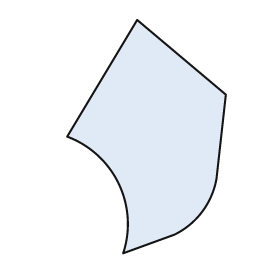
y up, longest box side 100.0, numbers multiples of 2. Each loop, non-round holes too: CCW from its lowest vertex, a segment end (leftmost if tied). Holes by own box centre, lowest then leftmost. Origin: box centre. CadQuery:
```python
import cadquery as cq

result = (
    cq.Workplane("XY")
    .moveTo(-10.0, -50.0)
    .lineTo(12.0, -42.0)
    .threePointArc((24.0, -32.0), (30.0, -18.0))
    .lineTo(34.0, 18.0)
    .lineTo(-4.0, 50.0)
    .lineTo(-34.0, 0.0)
    .threePointArc((-12.0, -20.0), (-10.0, -50.0))
    .close()
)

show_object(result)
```